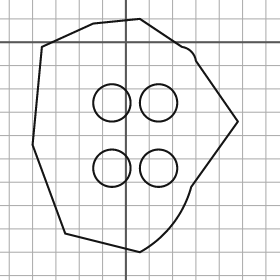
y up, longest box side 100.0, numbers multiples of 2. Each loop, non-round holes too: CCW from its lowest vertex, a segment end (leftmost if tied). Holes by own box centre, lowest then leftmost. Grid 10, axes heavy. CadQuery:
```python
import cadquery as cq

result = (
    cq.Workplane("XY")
    .moveTo(6.0, -90.0)
    .threePointArc((20.0, -78.0), (28.0, -62.0))
    .lineTo(48.0, -34.0)
    .lineTo(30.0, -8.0)
    .threePointArc((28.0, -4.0), (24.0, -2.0))
    .lineTo(6.0, 10.0)
    .lineTo(-14.0, 8.0)
    .lineTo(-36.0, -2.0)
    .lineTo(-40.0, -44.0)
    .lineTo(-26.0, -82.0)
    .close()
    .moveTo(-6.0, -54.0)
    .circle(8.0)
    .moveTo(14.0, -54.0)
    .circle(8.0)
    .moveTo(-6.0, -26.0)
    .circle(8.0)
    .moveTo(14.0, -26.0)
    .circle(8.0)
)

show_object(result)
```